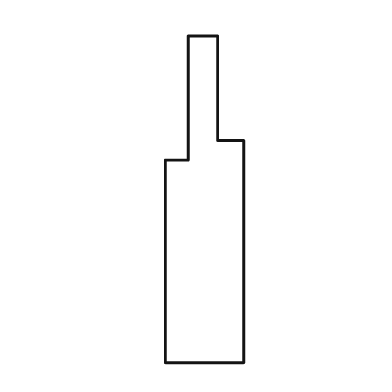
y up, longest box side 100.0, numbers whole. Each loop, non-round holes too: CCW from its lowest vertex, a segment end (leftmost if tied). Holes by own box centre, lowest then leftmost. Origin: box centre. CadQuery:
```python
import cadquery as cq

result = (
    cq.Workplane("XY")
    .moveTo(-12.0, -50.0)
    .lineTo(12.0, -50.0)
    .lineTo(12.0, 18.0)
    .lineTo(4.0, 18.0)
    .lineTo(4.0, 50.0)
    .lineTo(-5.0, 50.0)
    .lineTo(-5.0, 12.0)
    .lineTo(-12.0, 12.0)
    .close()
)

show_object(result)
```